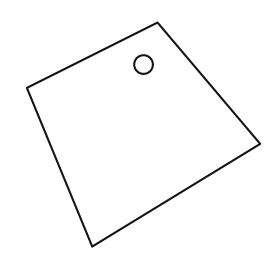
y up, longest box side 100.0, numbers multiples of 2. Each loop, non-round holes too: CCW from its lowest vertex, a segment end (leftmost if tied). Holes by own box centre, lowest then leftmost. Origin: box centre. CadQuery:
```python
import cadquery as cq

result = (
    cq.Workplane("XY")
    .moveTo(-22.0, -48.0)
    .lineTo(50.0, -4.0)
    .lineTo(6.0, 48.0)
    .lineTo(-50.0, 20.0)
    .close()
    .moveTo(0.0, 30.0)
    .circle(4.0)
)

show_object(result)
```